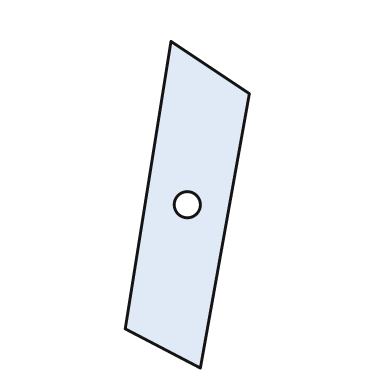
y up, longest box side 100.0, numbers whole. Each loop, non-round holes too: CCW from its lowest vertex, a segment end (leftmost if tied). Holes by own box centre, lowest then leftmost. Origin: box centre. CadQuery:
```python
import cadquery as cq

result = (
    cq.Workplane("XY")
    .moveTo(4.0, -50.0)
    .lineTo(19.0, 34.0)
    .lineTo(-5.0, 50.0)
    .lineTo(-19.0, -38.0)
    .close()
    .moveTo(0.0, 0.0)
    .circle(4.0)
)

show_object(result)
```